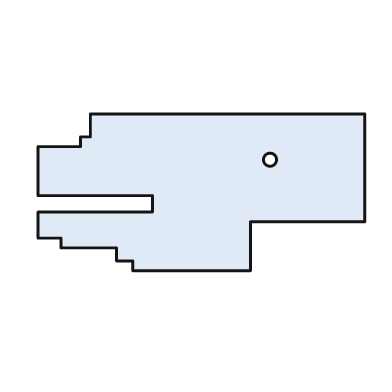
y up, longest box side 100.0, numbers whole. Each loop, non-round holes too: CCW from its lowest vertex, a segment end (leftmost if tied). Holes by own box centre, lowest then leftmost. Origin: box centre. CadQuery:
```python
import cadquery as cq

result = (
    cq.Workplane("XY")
    .moveTo(-21.0, -24.0)
    .lineTo(15.0, -24.0)
    .lineTo(15.0, -9.0)
    .lineTo(50.0, -9.0)
    .lineTo(50.0, 24.0)
    .lineTo(-34.0, 24.0)
    .lineTo(-34.0, 17.0)
    .lineTo(-37.0, 17.0)
    .lineTo(-37.0, 14.0)
    .lineTo(-50.0, 14.0)
    .lineTo(-50.0, -1.0)
    .lineTo(-15.0, -1.0)
    .lineTo(-15.0, -6.0)
    .lineTo(-50.0, -6.0)
    .lineTo(-50.0, -14.0)
    .lineTo(-43.0, -14.0)
    .lineTo(-43.0, -17.0)
    .lineTo(-26.0, -17.0)
    .lineTo(-26.0, -21.0)
    .lineTo(-21.0, -21.0)
    .close()
    .moveTo(21.0, 10.0)
    .circle(2.0)
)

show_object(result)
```